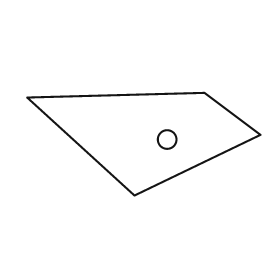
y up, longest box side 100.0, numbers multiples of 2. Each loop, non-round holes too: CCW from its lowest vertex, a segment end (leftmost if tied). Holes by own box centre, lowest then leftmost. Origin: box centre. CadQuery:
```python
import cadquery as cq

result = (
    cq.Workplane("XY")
    .moveTo(-4.0, -22.0)
    .lineTo(50.0, 4.0)
    .lineTo(26.0, 22.0)
    .lineTo(-50.0, 20.0)
    .close()
    .moveTo(10.0, 2.0)
    .circle(4.0)
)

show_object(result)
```